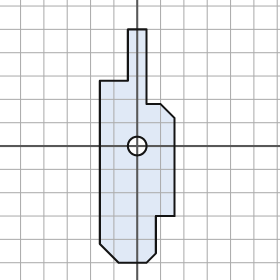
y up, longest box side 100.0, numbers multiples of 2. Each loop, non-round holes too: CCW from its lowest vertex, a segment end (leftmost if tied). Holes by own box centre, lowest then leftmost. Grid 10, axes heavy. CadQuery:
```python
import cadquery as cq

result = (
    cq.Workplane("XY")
    .moveTo(-8.0, -50.0)
    .lineTo(4.0, -50.0)
    .lineTo(8.0, -46.0)
    .lineTo(8.0, -30.0)
    .lineTo(16.0, -30.0)
    .lineTo(16.0, 12.0)
    .lineTo(10.0, 18.0)
    .lineTo(4.0, 18.0)
    .lineTo(4.0, 50.0)
    .lineTo(-4.0, 50.0)
    .lineTo(-4.0, 28.0)
    .lineTo(-16.0, 28.0)
    .lineTo(-16.0, -42.0)
    .close()
    .moveTo(0.0, 0.0)
    .circle(4.0)
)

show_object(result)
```